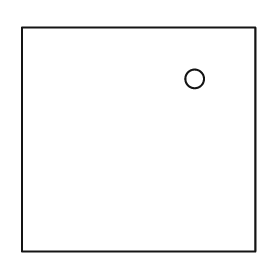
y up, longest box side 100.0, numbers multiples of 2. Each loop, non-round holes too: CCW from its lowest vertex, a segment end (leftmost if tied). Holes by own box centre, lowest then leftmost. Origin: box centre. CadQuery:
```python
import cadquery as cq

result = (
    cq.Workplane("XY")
    .moveTo(-50.0, -48.0)
    .lineTo(50.0, -48.0)
    .lineTo(50.0, 48.0)
    .lineTo(-50.0, 48.0)
    .close()
    .moveTo(24.0, 26.0)
    .circle(4.0)
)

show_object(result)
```